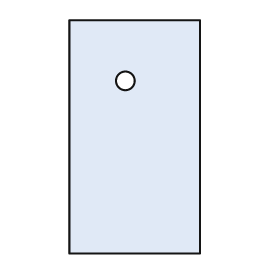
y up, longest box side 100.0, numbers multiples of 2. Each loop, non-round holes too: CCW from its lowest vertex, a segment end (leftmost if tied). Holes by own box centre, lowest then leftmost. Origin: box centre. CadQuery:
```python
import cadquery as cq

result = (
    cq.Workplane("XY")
    .moveTo(-28.0, -50.0)
    .lineTo(28.0, -50.0)
    .lineTo(28.0, 50.0)
    .lineTo(-28.0, 50.0)
    .close()
    .moveTo(-4.0, 24.0)
    .circle(4.0)
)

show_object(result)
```